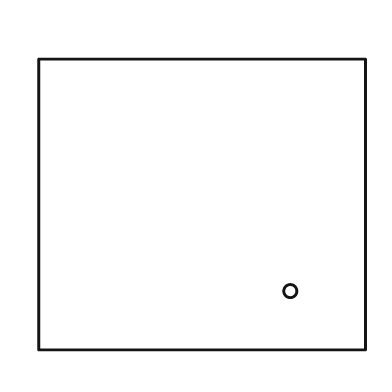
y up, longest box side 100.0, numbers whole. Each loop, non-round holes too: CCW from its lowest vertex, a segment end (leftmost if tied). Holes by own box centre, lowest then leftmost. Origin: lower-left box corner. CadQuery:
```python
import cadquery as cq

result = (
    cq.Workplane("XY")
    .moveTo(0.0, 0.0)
    .lineTo(100.0, 0.0)
    .lineTo(100.0, 89.0)
    .lineTo(0.0, 89.0)
    .close()
    .moveTo(77.0, 18.0)
    .circle(2.0)
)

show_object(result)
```